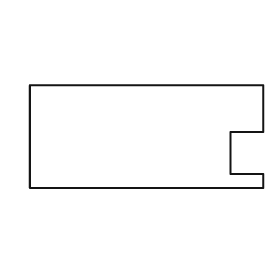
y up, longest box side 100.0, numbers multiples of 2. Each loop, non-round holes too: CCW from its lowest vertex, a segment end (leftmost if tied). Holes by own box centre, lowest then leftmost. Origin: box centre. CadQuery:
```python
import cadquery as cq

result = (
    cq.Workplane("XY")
    .moveTo(-50.0, -22.0)
    .lineTo(50.0, -22.0)
    .lineTo(50.0, -16.0)
    .lineTo(36.0, -16.0)
    .lineTo(36.0, 2.0)
    .lineTo(50.0, 2.0)
    .lineTo(50.0, 22.0)
    .lineTo(-50.0, 22.0)
    .close()
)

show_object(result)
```